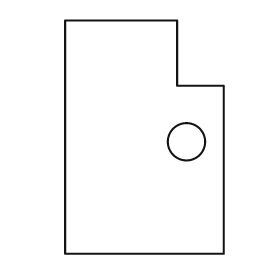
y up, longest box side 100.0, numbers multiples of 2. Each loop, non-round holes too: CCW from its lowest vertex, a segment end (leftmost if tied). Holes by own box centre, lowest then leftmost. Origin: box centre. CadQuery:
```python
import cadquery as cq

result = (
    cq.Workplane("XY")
    .moveTo(-34.0, -50.0)
    .lineTo(34.0, -50.0)
    .lineTo(34.0, 22.0)
    .lineTo(14.0, 22.0)
    .lineTo(14.0, 50.0)
    .lineTo(-34.0, 50.0)
    .close()
    .moveTo(18.0, -2.0)
    .circle(8.0)
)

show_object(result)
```